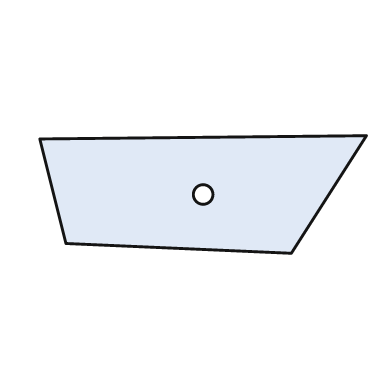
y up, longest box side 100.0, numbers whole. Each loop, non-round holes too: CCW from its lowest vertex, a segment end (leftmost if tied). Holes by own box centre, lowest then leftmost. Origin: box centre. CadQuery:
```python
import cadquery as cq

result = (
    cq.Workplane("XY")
    .moveTo(27.0, -18.0)
    .lineTo(50.0, 18.0)
    .lineTo(-50.0, 17.0)
    .lineTo(-42.0, -15.0)
    .close()
    .moveTo(0.0, 0.0)
    .circle(3.0)
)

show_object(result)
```